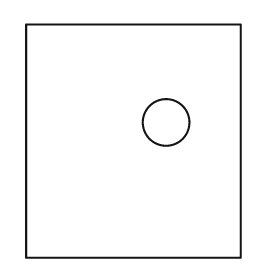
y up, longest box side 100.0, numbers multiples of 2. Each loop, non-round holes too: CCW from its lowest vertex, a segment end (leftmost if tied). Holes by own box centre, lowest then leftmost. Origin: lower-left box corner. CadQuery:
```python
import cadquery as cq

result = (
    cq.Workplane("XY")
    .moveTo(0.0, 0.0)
    .lineTo(92.0, 0.0)
    .lineTo(92.0, 100.0)
    .lineTo(0.0, 100.0)
    .close()
    .moveTo(60.0, 58.0)
    .circle(10.0)
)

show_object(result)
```